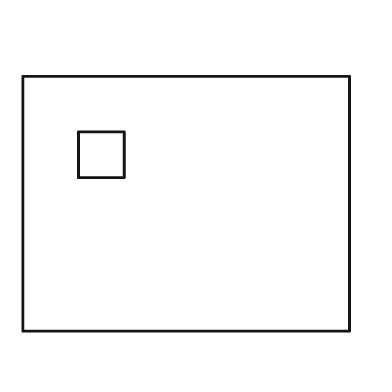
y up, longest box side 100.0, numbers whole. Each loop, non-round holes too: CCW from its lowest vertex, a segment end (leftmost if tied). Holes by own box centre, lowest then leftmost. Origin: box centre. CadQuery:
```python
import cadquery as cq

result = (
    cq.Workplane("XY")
    .moveTo(-50.0, -39.0)
    .lineTo(50.0, -39.0)
    .lineTo(50.0, 39.0)
    .lineTo(-50.0, 39.0)
    .close()
    .moveTo(-33.0, 8.0)
    .lineTo(-19.0, 8.0)
    .lineTo(-19.0, 22.0)
    .lineTo(-33.0, 22.0)
    .close()
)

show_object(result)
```